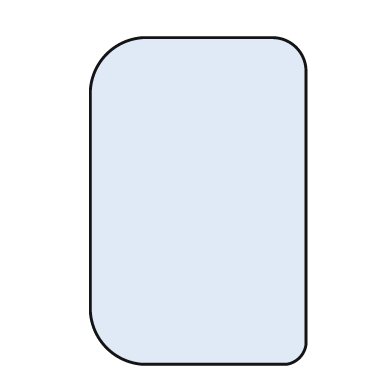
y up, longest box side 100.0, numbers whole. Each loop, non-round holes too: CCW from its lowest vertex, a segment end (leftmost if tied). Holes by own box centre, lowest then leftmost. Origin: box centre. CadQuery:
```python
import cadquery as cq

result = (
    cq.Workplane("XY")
    .moveTo(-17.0, -50.0)
    .lineTo(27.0, -50.0)
    .threePointArc((31.0, -48.0), (33.0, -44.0))
    .lineTo(33.0, 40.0)
    .threePointArc((30.0, 47.0), (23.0, 50.0))
    .lineTo(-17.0, 50.0)
    .threePointArc((-28.0, 45.0), (-33.0, 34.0))
    .lineTo(-33.0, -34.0)
    .threePointArc((-28.0, -45.0), (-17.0, -50.0))
    .close()
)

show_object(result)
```